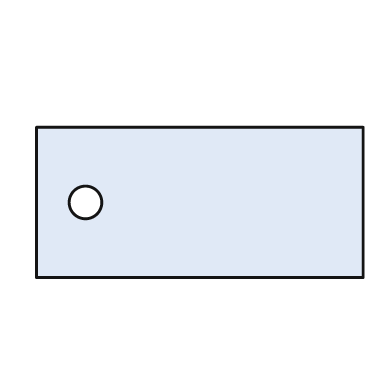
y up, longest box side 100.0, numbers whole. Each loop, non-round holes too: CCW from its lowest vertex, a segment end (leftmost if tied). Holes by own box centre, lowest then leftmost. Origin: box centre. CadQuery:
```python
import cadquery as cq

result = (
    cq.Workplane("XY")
    .moveTo(-50.0, -23.0)
    .lineTo(50.0, -23.0)
    .lineTo(50.0, 23.0)
    .lineTo(-50.0, 23.0)
    .close()
    .moveTo(-35.0, 0.0)
    .circle(5.0)
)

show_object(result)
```